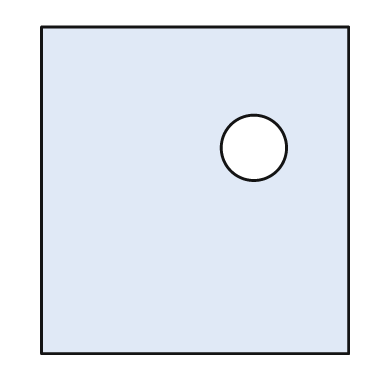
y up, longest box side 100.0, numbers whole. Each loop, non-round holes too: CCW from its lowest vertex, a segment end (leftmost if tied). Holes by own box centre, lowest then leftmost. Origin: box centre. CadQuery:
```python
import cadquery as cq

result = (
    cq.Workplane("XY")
    .moveTo(-47.0, -50.0)
    .lineTo(47.0, -50.0)
    .lineTo(47.0, 50.0)
    .lineTo(-47.0, 50.0)
    .close()
    .moveTo(18.0, 13.0)
    .circle(10.0)
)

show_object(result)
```